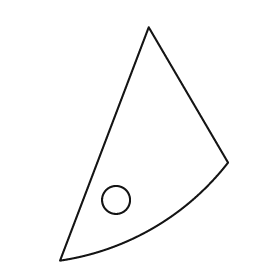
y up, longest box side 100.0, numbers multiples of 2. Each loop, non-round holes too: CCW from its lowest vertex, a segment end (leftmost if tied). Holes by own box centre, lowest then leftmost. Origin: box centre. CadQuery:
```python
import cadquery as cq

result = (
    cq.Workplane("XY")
    .moveTo(-36.0, -50.0)
    .threePointArc((4.0, -36.0), (36.0, -8.0))
    .lineTo(2.0, 50.0)
    .close()
    .moveTo(-12.0, -24.0)
    .circle(6.0)
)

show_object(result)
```